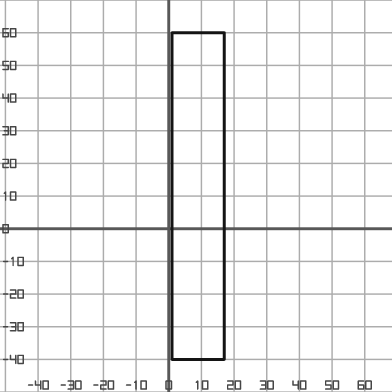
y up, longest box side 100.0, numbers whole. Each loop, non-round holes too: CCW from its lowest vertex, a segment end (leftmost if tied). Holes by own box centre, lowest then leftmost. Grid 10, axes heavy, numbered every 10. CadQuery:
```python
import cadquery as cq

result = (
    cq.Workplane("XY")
    .moveTo(1.0, -40.0)
    .lineTo(17.0, -40.0)
    .lineTo(17.0, 60.0)
    .lineTo(1.0, 60.0)
    .close()
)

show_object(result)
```